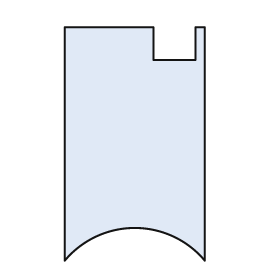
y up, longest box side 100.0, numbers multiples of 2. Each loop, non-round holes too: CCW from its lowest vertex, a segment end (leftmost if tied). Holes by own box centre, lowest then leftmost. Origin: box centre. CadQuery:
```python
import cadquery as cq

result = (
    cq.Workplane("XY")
    .moveTo(-30.0, -50.0)
    .threePointArc((0.0, -36.0), (30.0, -50.0))
    .lineTo(30.0, 50.0)
    .lineTo(26.0, 50.0)
    .lineTo(26.0, 36.0)
    .lineTo(8.0, 36.0)
    .lineTo(8.0, 50.0)
    .lineTo(-30.0, 50.0)
    .close()
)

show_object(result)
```